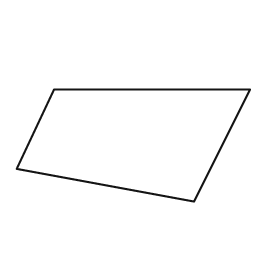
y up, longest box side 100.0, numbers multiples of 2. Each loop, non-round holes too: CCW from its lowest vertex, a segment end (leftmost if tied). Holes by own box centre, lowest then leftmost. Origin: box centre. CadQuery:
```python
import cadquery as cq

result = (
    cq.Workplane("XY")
    .moveTo(26.0, -24.0)
    .lineTo(50.0, 24.0)
    .lineTo(-34.0, 24.0)
    .lineTo(-50.0, -10.0)
    .close()
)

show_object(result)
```